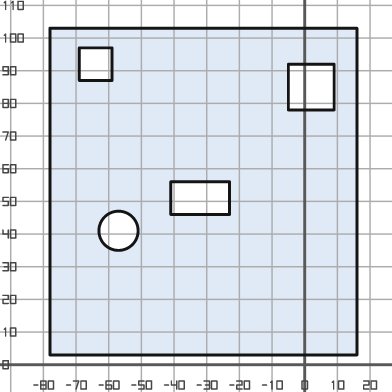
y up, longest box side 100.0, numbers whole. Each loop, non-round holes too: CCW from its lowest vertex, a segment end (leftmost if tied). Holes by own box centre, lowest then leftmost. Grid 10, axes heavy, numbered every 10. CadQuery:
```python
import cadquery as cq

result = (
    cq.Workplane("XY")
    .moveTo(-78.0, 3.0)
    .lineTo(16.0, 3.0)
    .lineTo(16.0, 103.0)
    .lineTo(-78.0, 103.0)
    .close()
    .moveTo(-57.0, 41.0)
    .circle(6.0)
    .moveTo(-41.0, 46.0)
    .lineTo(-23.0, 46.0)
    .lineTo(-23.0, 56.0)
    .lineTo(-41.0, 56.0)
    .close()
    .moveTo(-5.0, 78.0)
    .lineTo(9.0, 78.0)
    .lineTo(9.0, 92.0)
    .lineTo(-5.0, 92.0)
    .close()
    .moveTo(-69.0, 87.0)
    .lineTo(-59.0, 87.0)
    .lineTo(-59.0, 97.0)
    .lineTo(-69.0, 97.0)
    .close()
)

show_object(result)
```